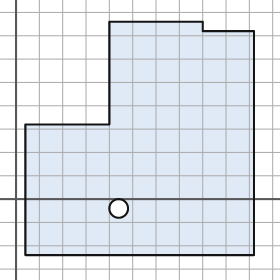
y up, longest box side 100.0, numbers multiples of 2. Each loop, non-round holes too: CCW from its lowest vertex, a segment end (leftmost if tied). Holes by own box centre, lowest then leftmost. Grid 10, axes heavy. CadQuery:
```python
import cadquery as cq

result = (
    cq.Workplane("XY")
    .moveTo(4.0, -24.0)
    .lineTo(102.0, -24.0)
    .lineTo(102.0, 72.0)
    .lineTo(80.0, 72.0)
    .lineTo(80.0, 76.0)
    .lineTo(40.0, 76.0)
    .lineTo(40.0, 32.0)
    .lineTo(4.0, 32.0)
    .close()
    .moveTo(44.0, -4.0)
    .circle(4.0)
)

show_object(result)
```